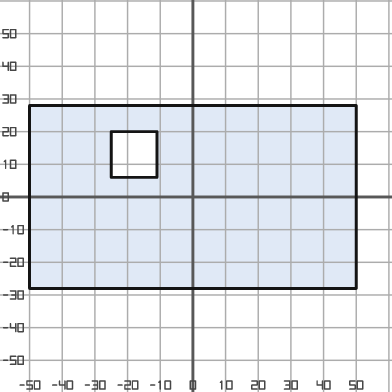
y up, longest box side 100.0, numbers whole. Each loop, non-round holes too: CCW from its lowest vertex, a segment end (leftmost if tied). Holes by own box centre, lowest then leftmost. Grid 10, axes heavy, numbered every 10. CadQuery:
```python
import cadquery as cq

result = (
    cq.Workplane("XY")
    .moveTo(-50.0, -28.0)
    .lineTo(50.0, -28.0)
    .lineTo(50.0, 28.0)
    .lineTo(-50.0, 28.0)
    .close()
    .moveTo(-25.0, 6.0)
    .lineTo(-11.0, 6.0)
    .lineTo(-11.0, 20.0)
    .lineTo(-25.0, 20.0)
    .close()
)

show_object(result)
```